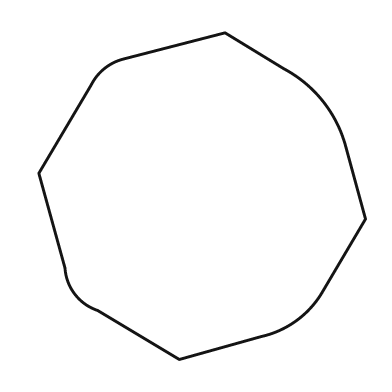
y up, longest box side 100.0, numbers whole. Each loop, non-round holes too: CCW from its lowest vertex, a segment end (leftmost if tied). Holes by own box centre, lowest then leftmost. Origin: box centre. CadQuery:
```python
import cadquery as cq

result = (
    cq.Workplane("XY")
    .moveTo(-7.0, -50.0)
    .lineTo(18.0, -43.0)
    .threePointArc((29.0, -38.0), (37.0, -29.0))
    .lineTo(50.0, -7.0)
    .lineTo(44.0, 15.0)
    .threePointArc((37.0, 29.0), (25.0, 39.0))
    .lineTo(7.0, 50.0)
    .lineTo(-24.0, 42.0)
    .threePointArc((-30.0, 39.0), (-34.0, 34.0))
    .lineTo(-50.0, 7.0)
    .lineTo(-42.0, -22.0)
    .threePointArc((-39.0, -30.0), (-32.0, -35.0))
    .close()
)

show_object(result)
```